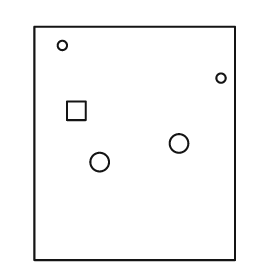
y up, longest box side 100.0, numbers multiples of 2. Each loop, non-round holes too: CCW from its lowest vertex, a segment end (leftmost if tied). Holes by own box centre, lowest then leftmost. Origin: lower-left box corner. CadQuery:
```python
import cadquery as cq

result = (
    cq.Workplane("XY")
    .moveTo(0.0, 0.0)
    .lineTo(86.0, 0.0)
    .lineTo(86.0, 100.0)
    .lineTo(0.0, 100.0)
    .close()
    .moveTo(28.0, 42.0)
    .circle(4.0)
    .moveTo(62.0, 50.0)
    .circle(4.0)
    .moveTo(14.0, 60.0)
    .lineTo(22.0, 60.0)
    .lineTo(22.0, 68.0)
    .lineTo(14.0, 68.0)
    .close()
    .moveTo(80.0, 78.0)
    .circle(2.0)
    .moveTo(12.0, 92.0)
    .circle(2.0)
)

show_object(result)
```